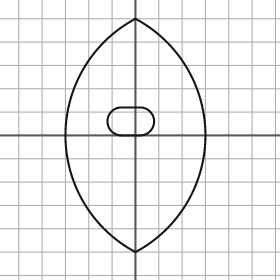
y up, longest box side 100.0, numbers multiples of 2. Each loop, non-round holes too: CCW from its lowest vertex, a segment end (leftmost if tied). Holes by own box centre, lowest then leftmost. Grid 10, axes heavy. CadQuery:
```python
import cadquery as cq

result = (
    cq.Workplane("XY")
    .moveTo(0.0, -50.0)
    .threePointArc((30.0, 0.0), (0.0, 50.0))
    .threePointArc((-30.0, 0.0), (0.0, -50.0))
    .close()
    .moveTo(-6.0, 0.0)
    .lineTo(2.0, 0.0)
    .threePointArc((8.0, 6.0), (2.0, 12.0))
    .lineTo(-6.0, 12.0)
    .threePointArc((-12.0, 6.0), (-6.0, 0.0))
    .close()
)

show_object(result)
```